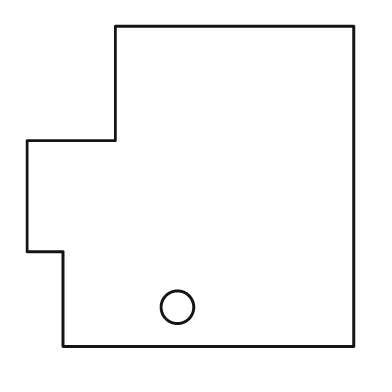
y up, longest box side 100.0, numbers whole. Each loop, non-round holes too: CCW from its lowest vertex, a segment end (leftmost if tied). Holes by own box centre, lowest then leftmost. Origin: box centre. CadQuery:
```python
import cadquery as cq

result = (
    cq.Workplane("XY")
    .moveTo(-39.0, -49.0)
    .lineTo(50.0, -49.0)
    .lineTo(50.0, 49.0)
    .lineTo(-23.0, 49.0)
    .lineTo(-23.0, 14.0)
    .lineTo(-50.0, 14.0)
    .lineTo(-50.0, -20.0)
    .lineTo(-39.0, -20.0)
    .close()
    .moveTo(-4.0, -37.0)
    .circle(5.0)
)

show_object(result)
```